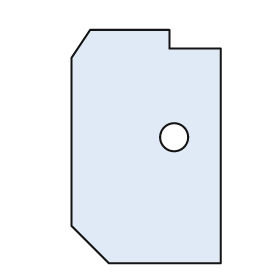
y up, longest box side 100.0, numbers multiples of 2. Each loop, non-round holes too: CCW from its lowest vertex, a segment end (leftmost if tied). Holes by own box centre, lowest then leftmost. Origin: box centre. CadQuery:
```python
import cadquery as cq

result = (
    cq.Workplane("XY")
    .moveTo(-16.0, -50.0)
    .lineTo(32.0, -50.0)
    .lineTo(32.0, 42.0)
    .lineTo(10.0, 42.0)
    .lineTo(10.0, 50.0)
    .lineTo(-24.0, 50.0)
    .lineTo(-32.0, 38.0)
    .lineTo(-32.0, -34.0)
    .close()
    .moveTo(12.0, 4.0)
    .circle(6.0)
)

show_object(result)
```